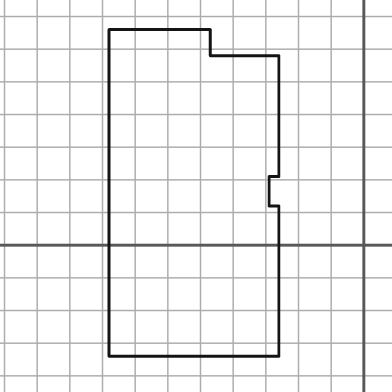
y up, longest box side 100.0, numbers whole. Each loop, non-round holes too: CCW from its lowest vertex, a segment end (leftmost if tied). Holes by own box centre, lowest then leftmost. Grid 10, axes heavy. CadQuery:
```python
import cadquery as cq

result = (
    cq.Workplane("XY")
    .moveTo(-78.0, -34.0)
    .lineTo(-26.0, -34.0)
    .lineTo(-26.0, 12.0)
    .lineTo(-29.0, 12.0)
    .lineTo(-29.0, 21.0)
    .lineTo(-26.0, 21.0)
    .lineTo(-26.0, 58.0)
    .lineTo(-47.0, 58.0)
    .lineTo(-47.0, 66.0)
    .lineTo(-78.0, 66.0)
    .close()
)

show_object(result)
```